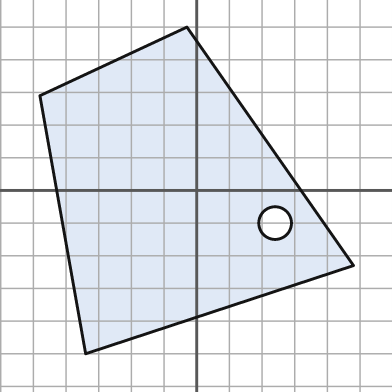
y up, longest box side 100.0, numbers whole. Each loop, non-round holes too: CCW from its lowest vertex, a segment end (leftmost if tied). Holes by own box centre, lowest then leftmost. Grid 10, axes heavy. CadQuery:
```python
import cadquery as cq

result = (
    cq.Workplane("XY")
    .moveTo(-34.0, -50.0)
    .lineTo(48.0, -23.0)
    .lineTo(-3.0, 50.0)
    .lineTo(-48.0, 29.0)
    .close()
    .moveTo(24.0, -10.0)
    .circle(5.0)
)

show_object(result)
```